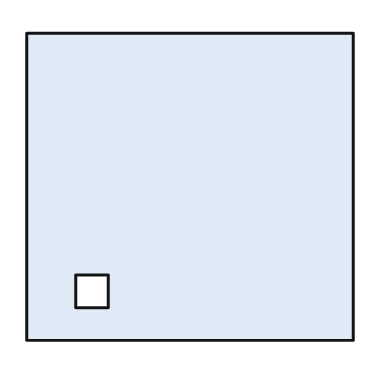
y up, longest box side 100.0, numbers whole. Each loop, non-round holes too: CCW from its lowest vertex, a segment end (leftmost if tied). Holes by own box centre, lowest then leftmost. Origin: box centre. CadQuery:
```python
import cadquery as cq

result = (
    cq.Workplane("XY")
    .moveTo(-50.0, -47.0)
    .lineTo(50.0, -47.0)
    .lineTo(50.0, 47.0)
    .lineTo(-50.0, 47.0)
    .close()
    .moveTo(-35.0, -37.0)
    .lineTo(-25.0, -37.0)
    .lineTo(-25.0, -27.0)
    .lineTo(-35.0, -27.0)
    .close()
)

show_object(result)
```